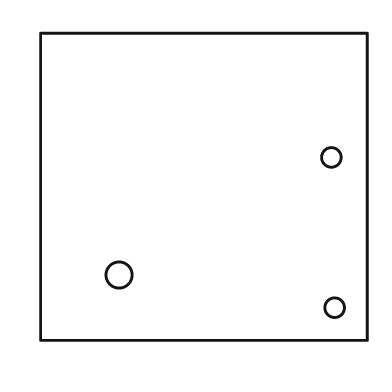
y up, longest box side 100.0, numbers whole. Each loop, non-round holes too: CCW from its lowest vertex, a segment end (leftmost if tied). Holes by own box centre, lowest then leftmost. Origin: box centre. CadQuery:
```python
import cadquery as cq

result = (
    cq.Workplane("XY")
    .moveTo(-50.0, -47.0)
    .lineTo(50.0, -47.0)
    .lineTo(50.0, 47.0)
    .lineTo(-50.0, 47.0)
    .close()
    .moveTo(40.0, -37.0)
    .circle(3.0)
    .moveTo(-26.0, -27.0)
    .circle(4.0)
    .moveTo(39.0, 9.0)
    .circle(3.0)
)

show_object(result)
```